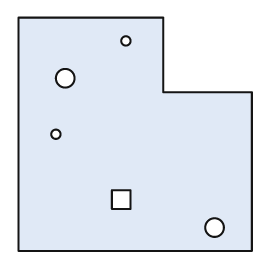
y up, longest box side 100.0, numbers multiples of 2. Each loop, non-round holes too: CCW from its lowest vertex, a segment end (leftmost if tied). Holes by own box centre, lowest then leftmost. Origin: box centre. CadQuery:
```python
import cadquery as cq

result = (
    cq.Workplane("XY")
    .moveTo(-50.0, -50.0)
    .lineTo(50.0, -50.0)
    .lineTo(50.0, 18.0)
    .lineTo(12.0, 18.0)
    .lineTo(12.0, 50.0)
    .lineTo(-50.0, 50.0)
    .close()
    .moveTo(34.0, -40.0)
    .circle(4.0)
    .moveTo(-10.0, -32.0)
    .lineTo(-2.0, -32.0)
    .lineTo(-2.0, -24.0)
    .lineTo(-10.0, -24.0)
    .close()
    .moveTo(-34.0, 0.0)
    .circle(2.0)
    .moveTo(-30.0, 24.0)
    .circle(4.0)
    .moveTo(-4.0, 40.0)
    .circle(2.0)
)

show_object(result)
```